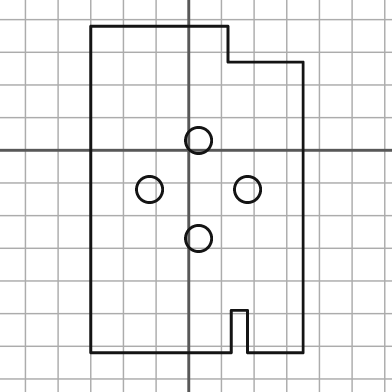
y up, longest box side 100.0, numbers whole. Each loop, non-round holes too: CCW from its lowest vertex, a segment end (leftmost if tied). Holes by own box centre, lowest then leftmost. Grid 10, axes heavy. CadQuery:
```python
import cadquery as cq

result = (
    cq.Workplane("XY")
    .moveTo(-30.0, -62.0)
    .lineTo(13.0, -62.0)
    .lineTo(13.0, -49.0)
    .lineTo(18.0, -49.0)
    .lineTo(18.0, -62.0)
    .lineTo(35.0, -62.0)
    .lineTo(35.0, 27.0)
    .lineTo(12.0, 27.0)
    .lineTo(12.0, 38.0)
    .lineTo(-30.0, 38.0)
    .close()
    .moveTo(3.0, -27.0)
    .circle(4.0)
    .moveTo(-12.0, -12.0)
    .circle(4.0)
    .moveTo(18.0, -12.0)
    .circle(4.0)
    .moveTo(3.0, 3.0)
    .circle(4.0)
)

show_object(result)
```